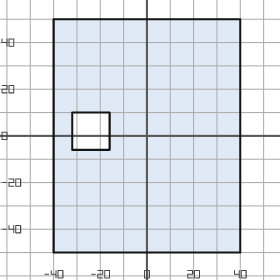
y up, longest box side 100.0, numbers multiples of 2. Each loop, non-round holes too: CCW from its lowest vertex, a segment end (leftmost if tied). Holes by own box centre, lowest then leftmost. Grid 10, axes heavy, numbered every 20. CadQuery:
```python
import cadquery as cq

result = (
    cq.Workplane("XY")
    .moveTo(-40.0, -50.0)
    .lineTo(40.0, -50.0)
    .lineTo(40.0, 50.0)
    .lineTo(-40.0, 50.0)
    .close()
    .moveTo(-32.0, -6.0)
    .lineTo(-16.0, -6.0)
    .lineTo(-16.0, 10.0)
    .lineTo(-32.0, 10.0)
    .close()
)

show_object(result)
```